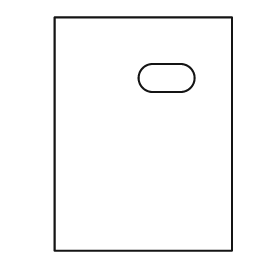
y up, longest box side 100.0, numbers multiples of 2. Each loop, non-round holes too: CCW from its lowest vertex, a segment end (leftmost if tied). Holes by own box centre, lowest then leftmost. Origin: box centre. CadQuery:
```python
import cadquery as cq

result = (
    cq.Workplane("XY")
    .moveTo(-38.0, -50.0)
    .lineTo(38.0, -50.0)
    .lineTo(38.0, 50.0)
    .lineTo(-38.0, 50.0)
    .close()
    .moveTo(4.0, 18.0)
    .lineTo(16.0, 18.0)
    .threePointArc((22.0, 24.0), (16.0, 30.0))
    .lineTo(4.0, 30.0)
    .threePointArc((-2.0, 24.0), (4.0, 18.0))
    .close()
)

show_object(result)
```